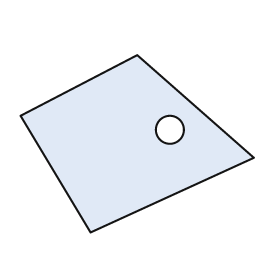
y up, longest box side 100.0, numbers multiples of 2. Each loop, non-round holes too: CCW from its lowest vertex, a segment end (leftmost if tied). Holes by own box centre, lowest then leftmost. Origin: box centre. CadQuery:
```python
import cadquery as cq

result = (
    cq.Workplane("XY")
    .moveTo(-20.0, -38.0)
    .lineTo(50.0, -6.0)
    .lineTo(0.0, 38.0)
    .lineTo(-50.0, 12.0)
    .close()
    .moveTo(14.0, 6.0)
    .circle(6.0)
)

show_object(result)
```